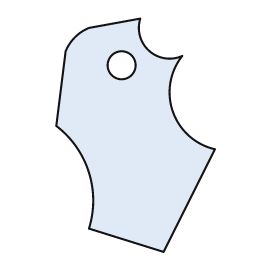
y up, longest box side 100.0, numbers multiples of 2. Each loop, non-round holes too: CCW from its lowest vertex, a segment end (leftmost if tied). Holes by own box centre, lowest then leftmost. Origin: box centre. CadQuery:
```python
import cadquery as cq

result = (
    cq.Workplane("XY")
    .moveTo(12.0, -50.0)
    .lineTo(34.0, -6.0)
    .threePointArc((16.0, 10.0), (20.0, 34.0))
    .threePointArc((6.0, 36.0), (2.0, 50.0))
    .lineTo(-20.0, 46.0)
    .threePointArc((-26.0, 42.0), (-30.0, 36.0))
    .lineTo(-34.0, 4.0)
    .threePointArc((-20.0, -16.0), (-20.0, -40.0))
    .close()
    .moveTo(-6.0, 30.0)
    .circle(6.0)
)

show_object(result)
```